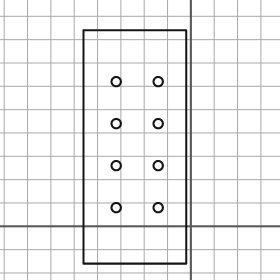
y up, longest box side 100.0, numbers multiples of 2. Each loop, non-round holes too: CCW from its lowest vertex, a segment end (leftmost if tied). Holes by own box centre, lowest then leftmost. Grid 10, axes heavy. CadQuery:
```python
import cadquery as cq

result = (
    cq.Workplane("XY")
    .moveTo(-46.0, -16.0)
    .lineTo(-2.0, -16.0)
    .lineTo(-2.0, 84.0)
    .lineTo(-46.0, 84.0)
    .close()
    .moveTo(-32.0, 8.0)
    .circle(2.0)
    .moveTo(-14.0, 8.0)
    .circle(2.0)
    .moveTo(-32.0, 26.0)
    .circle(2.0)
    .moveTo(-14.0, 26.0)
    .circle(2.0)
    .moveTo(-32.0, 44.0)
    .circle(2.0)
    .moveTo(-14.0, 44.0)
    .circle(2.0)
    .moveTo(-32.0, 62.0)
    .circle(2.0)
    .moveTo(-14.0, 62.0)
    .circle(2.0)
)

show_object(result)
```